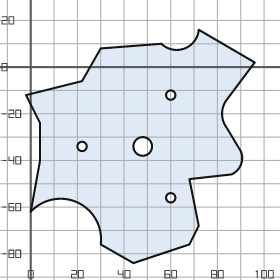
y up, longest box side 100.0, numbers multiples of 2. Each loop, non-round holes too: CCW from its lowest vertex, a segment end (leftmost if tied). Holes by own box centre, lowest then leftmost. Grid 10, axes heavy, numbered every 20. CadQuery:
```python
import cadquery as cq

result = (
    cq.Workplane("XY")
    .moveTo(44.0, -84.0)
    .lineTo(68.0, -76.0)
    .lineTo(72.0, -68.0)
    .lineTo(68.0, -48.0)
    .lineTo(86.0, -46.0)
    .threePointArc((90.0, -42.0), (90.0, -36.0))
    .lineTo(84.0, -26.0)
    .threePointArc((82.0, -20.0), (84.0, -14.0))
    .lineTo(96.0, 2.0)
    .lineTo(72.0, 16.0)
    .threePointArc((66.0, 8.0), (56.0, 10.0))
    .lineTo(30.0, 8.0)
    .lineTo(22.0, -6.0)
    .lineTo(-2.0, -12.0)
    .lineTo(4.0, -24.0)
    .lineTo(4.0, -40.0)
    .lineTo(0.0, -62.0)
    .threePointArc((20.0, -58.0), (30.0, -76.0))
    .close()
    .moveTo(60.0, -56.0)
    .circle(2.0)
    .moveTo(22.0, -34.0)
    .circle(2.0)
    .moveTo(48.0, -34.0)
    .circle(4.0)
    .moveTo(60.0, -12.0)
    .circle(2.0)
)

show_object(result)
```